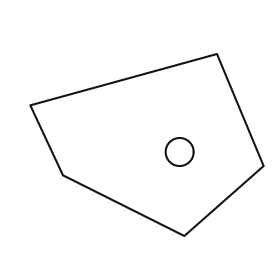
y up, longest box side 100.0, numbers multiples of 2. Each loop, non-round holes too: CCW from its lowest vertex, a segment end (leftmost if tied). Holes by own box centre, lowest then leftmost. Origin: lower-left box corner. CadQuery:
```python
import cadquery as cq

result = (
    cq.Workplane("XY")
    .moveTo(66.0, 0.0)
    .lineTo(100.0, 30.0)
    .lineTo(80.0, 78.0)
    .lineTo(0.0, 56.0)
    .lineTo(14.0, 26.0)
    .close()
    .moveTo(64.0, 36.0)
    .circle(6.0)
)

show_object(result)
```